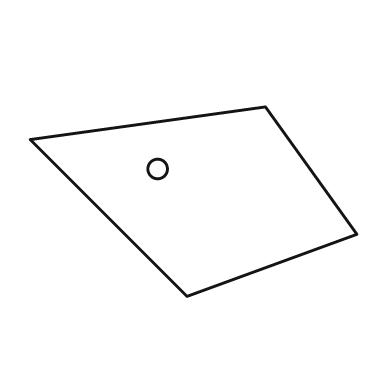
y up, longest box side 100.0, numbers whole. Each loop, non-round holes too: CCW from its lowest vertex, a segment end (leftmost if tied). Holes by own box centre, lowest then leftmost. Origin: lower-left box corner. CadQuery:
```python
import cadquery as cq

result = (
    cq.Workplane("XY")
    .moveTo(48.0, 0.0)
    .lineTo(100.0, 19.0)
    .lineTo(72.0, 58.0)
    .lineTo(0.0, 48.0)
    .close()
    .moveTo(39.0, 39.0)
    .circle(3.0)
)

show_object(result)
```